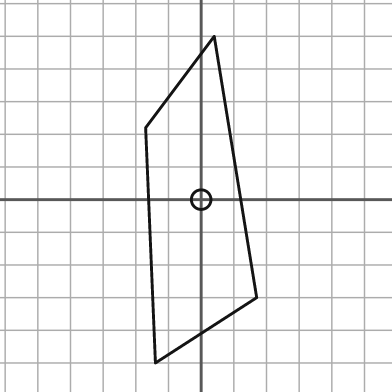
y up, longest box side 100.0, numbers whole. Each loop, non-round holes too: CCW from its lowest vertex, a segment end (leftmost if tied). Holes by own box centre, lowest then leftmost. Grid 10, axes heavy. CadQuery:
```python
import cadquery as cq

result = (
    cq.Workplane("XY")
    .moveTo(-14.0, -50.0)
    .lineTo(17.0, -30.0)
    .lineTo(4.0, 50.0)
    .lineTo(-17.0, 22.0)
    .close()
    .moveTo(0.0, 0.0)
    .circle(3.0)
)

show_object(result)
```